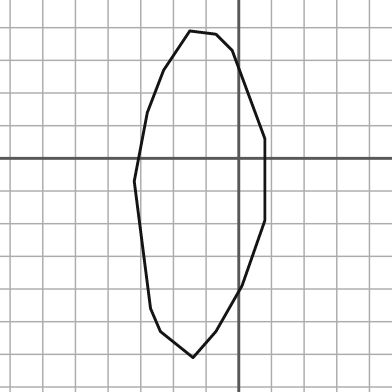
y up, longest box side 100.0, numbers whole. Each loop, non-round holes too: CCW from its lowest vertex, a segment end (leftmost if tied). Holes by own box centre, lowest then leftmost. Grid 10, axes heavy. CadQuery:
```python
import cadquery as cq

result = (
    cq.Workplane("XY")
    .moveTo(-14.0, -61.0)
    .lineTo(-7.0, -53.0)
    .lineTo(1.0, -39.0)
    .lineTo(8.0, -19.0)
    .lineTo(8.0, 6.0)
    .lineTo(-2.0, 33.0)
    .lineTo(-7.0, 38.0)
    .lineTo(-15.0, 39.0)
    .lineTo(-23.0, 27.0)
    .lineTo(-28.0, 14.0)
    .lineTo(-32.0, -7.0)
    .lineTo(-27.0, -46.0)
    .lineTo(-24.0, -53.0)
    .close()
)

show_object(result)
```